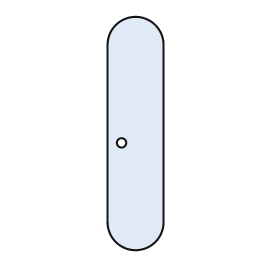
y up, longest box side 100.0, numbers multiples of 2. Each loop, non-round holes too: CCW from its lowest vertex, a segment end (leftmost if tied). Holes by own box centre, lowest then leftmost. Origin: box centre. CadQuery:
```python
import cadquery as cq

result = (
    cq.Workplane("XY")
    .moveTo(-12.0, -38.0)
    .threePointArc((0.0, -50.0), (12.0, -38.0))
    .lineTo(12.0, 38.0)
    .threePointArc((0.0, 50.0), (-12.0, 38.0))
    .close()
    .moveTo(-6.0, -4.0)
    .circle(2.0)
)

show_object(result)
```